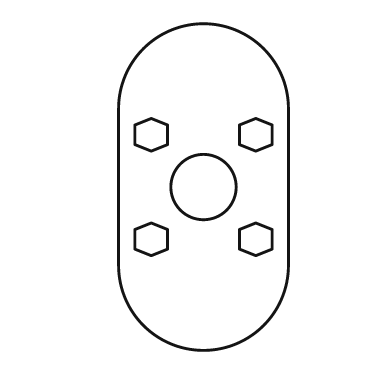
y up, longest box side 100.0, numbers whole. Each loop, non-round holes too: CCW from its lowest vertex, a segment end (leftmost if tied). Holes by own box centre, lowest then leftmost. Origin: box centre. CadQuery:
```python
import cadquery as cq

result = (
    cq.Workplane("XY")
    .moveTo(-26.0, -24.0)
    .threePointArc((0.0, -50.0), (26.0, -24.0))
    .lineTo(26.0, 24.0)
    .threePointArc((0.0, 50.0), (-26.0, 24.0))
    .close()
    .moveTo(-16.0, -21.0)
    .lineTo(-11.0, -19.0)
    .lineTo(-11.0, -13.0)
    .lineTo(-16.0, -11.0)
    .lineTo(-21.0, -13.0)
    .lineTo(-21.0, -19.0)
    .close()
    .moveTo(16.0, -21.0)
    .lineTo(21.0, -19.0)
    .lineTo(21.0, -13.0)
    .lineTo(16.0, -11.0)
    .lineTo(11.0, -13.0)
    .lineTo(11.0, -19.0)
    .close()
    .moveTo(0.0, 0.0)
    .circle(10.0)
    .moveTo(-16.0, 11.0)
    .lineTo(-11.0, 13.0)
    .lineTo(-11.0, 19.0)
    .lineTo(-16.0, 21.0)
    .lineTo(-21.0, 19.0)
    .lineTo(-21.0, 13.0)
    .close()
    .moveTo(16.0, 11.0)
    .lineTo(21.0, 13.0)
    .lineTo(21.0, 19.0)
    .lineTo(16.0, 21.0)
    .lineTo(11.0, 19.0)
    .lineTo(11.0, 13.0)
    .close()
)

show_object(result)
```